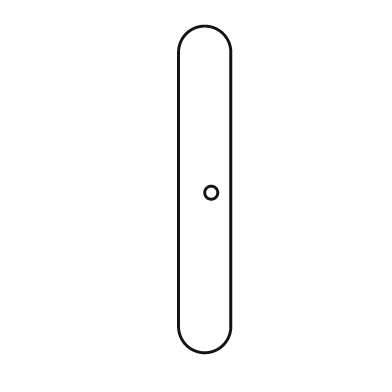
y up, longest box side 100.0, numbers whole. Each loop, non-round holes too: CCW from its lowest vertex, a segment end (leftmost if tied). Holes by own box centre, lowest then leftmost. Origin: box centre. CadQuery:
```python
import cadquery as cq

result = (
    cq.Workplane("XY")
    .moveTo(-8.0, -42.0)
    .threePointArc((0.0, -50.0), (8.0, -42.0))
    .lineTo(8.0, 42.0)
    .threePointArc((0.0, 50.0), (-8.0, 42.0))
    .close()
    .moveTo(2.0, -1.0)
    .circle(2.0)
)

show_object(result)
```